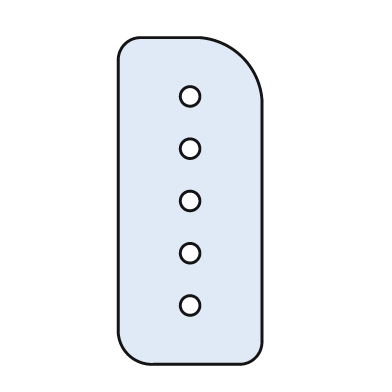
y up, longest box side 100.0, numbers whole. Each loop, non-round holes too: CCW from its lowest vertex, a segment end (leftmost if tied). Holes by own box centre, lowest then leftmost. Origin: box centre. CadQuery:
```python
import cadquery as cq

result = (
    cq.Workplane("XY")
    .moveTo(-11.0, -50.0)
    .lineTo(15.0, -50.0)
    .threePointArc((20.0, -48.0), (22.0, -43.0))
    .lineTo(22.0, 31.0)
    .threePointArc((16.0, 44.0), (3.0, 50.0))
    .lineTo(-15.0, 50.0)
    .threePointArc((-20.0, 48.0), (-22.0, 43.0))
    .lineTo(-22.0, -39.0)
    .threePointArc((-19.0, -47.0), (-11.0, -50.0))
    .close()
    .moveTo(0.0, -32.0)
    .circle(3.0)
    .moveTo(0.0, -16.0)
    .circle(3.0)
    .moveTo(0.0, 0.0)
    .circle(3.0)
    .moveTo(0.0, 16.0)
    .circle(3.0)
    .moveTo(0.0, 32.0)
    .circle(3.0)
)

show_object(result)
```